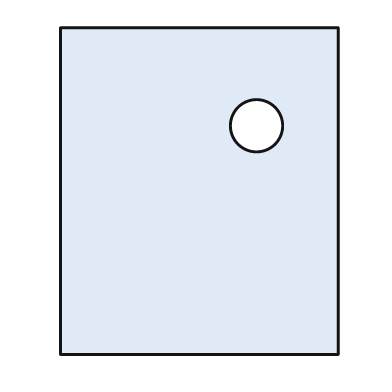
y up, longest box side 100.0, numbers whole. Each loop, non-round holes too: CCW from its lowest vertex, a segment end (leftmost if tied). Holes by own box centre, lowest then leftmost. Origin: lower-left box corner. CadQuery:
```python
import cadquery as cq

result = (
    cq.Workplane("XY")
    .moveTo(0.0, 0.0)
    .lineTo(85.0, 0.0)
    .lineTo(85.0, 100.0)
    .lineTo(0.0, 100.0)
    .close()
    .moveTo(60.0, 70.0)
    .circle(8.0)
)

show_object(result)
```